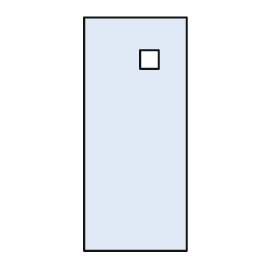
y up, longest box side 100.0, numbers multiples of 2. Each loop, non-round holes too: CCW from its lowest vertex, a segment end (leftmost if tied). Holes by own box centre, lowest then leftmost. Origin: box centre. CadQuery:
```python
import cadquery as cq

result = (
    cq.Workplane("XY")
    .moveTo(-22.0, -50.0)
    .lineTo(22.0, -50.0)
    .lineTo(22.0, 50.0)
    .lineTo(-22.0, 50.0)
    .close()
    .moveTo(2.0, 28.0)
    .lineTo(10.0, 28.0)
    .lineTo(10.0, 36.0)
    .lineTo(2.0, 36.0)
    .close()
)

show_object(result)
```